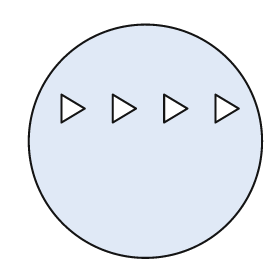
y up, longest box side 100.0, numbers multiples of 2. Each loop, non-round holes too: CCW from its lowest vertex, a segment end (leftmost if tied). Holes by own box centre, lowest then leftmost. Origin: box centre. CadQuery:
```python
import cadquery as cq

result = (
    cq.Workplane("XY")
    .moveTo(0.0, 0.0)
    .circle(50.0)
    .moveTo(-36.0, 8.0)
    .lineTo(-26.0, 14.0)
    .lineTo(-36.0, 20.0)
    .close()
    .moveTo(-14.0, 8.0)
    .lineTo(-4.0, 14.0)
    .lineTo(-14.0, 20.0)
    .close()
    .moveTo(8.0, 8.0)
    .lineTo(18.0, 14.0)
    .lineTo(8.0, 20.0)
    .close()
    .moveTo(30.0, 8.0)
    .lineTo(40.0, 14.0)
    .lineTo(30.0, 20.0)
    .close()
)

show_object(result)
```